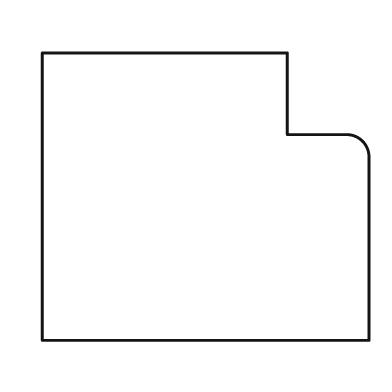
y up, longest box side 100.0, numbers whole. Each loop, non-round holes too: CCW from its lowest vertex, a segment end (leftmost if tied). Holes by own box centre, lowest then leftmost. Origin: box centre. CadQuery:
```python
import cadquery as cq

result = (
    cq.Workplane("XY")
    .moveTo(-50.0, -44.0)
    .lineTo(50.0, -44.0)
    .lineTo(50.0, 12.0)
    .threePointArc((48.0, 17.0), (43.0, 19.0))
    .lineTo(25.0, 19.0)
    .lineTo(25.0, 44.0)
    .lineTo(-50.0, 44.0)
    .close()
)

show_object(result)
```